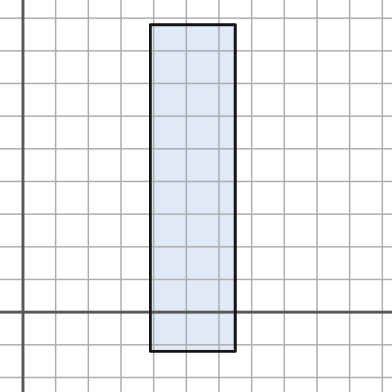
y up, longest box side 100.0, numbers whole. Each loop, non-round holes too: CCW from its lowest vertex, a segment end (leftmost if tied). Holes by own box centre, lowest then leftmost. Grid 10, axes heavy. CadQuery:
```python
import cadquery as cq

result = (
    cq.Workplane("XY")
    .moveTo(39.0, -12.0)
    .lineTo(65.0, -12.0)
    .lineTo(65.0, 88.0)
    .lineTo(39.0, 88.0)
    .close()
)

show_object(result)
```